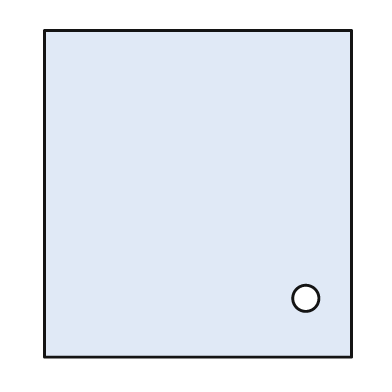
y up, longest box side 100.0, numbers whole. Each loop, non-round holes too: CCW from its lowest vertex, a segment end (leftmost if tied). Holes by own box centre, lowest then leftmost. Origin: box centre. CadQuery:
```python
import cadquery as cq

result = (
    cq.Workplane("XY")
    .moveTo(-47.0, -50.0)
    .lineTo(47.0, -50.0)
    .lineTo(47.0, 50.0)
    .lineTo(-47.0, 50.0)
    .close()
    .moveTo(33.0, -32.0)
    .circle(4.0)
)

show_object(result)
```